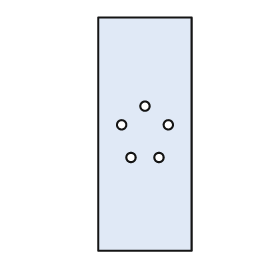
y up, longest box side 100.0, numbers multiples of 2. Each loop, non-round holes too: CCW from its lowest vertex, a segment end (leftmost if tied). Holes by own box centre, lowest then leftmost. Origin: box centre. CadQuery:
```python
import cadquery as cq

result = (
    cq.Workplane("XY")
    .moveTo(-20.0, -50.0)
    .lineTo(20.0, -50.0)
    .lineTo(20.0, 50.0)
    .lineTo(-20.0, 50.0)
    .close()
    .moveTo(-6.0, -10.0)
    .circle(2.0)
    .moveTo(6.0, -10.0)
    .circle(2.0)
    .moveTo(-10.0, 4.0)
    .circle(2.0)
    .moveTo(10.0, 4.0)
    .circle(2.0)
    .moveTo(0.0, 12.0)
    .circle(2.0)
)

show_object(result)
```